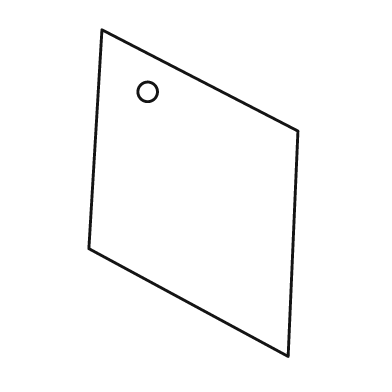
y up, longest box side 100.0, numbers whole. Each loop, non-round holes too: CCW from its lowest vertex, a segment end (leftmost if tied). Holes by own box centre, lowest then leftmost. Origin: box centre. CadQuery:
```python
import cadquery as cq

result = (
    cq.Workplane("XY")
    .moveTo(29.0, -50.0)
    .lineTo(32.0, 19.0)
    .lineTo(-28.0, 50.0)
    .lineTo(-32.0, -17.0)
    .close()
    .moveTo(-14.0, 31.0)
    .circle(3.0)
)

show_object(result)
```